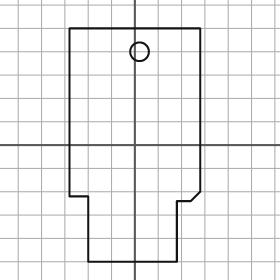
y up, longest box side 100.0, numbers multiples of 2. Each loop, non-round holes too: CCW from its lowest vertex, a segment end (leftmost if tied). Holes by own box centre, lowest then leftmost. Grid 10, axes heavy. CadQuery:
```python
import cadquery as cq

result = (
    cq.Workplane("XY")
    .moveTo(-20.0, -50.0)
    .lineTo(18.0, -50.0)
    .lineTo(18.0, -24.0)
    .lineTo(24.0, -24.0)
    .lineTo(28.0, -20.0)
    .lineTo(28.0, 50.0)
    .lineTo(-28.0, 50.0)
    .lineTo(-28.0, -22.0)
    .lineTo(-20.0, -22.0)
    .close()
    .moveTo(2.0, 40.0)
    .circle(4.0)
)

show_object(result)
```